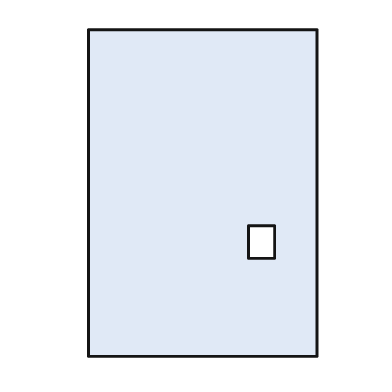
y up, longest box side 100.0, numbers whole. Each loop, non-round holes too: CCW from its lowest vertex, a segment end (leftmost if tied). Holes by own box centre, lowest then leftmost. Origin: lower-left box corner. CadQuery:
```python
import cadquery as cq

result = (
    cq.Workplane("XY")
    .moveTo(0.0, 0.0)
    .lineTo(70.0, 0.0)
    .lineTo(70.0, 100.0)
    .lineTo(0.0, 100.0)
    .close()
    .moveTo(49.0, 30.0)
    .lineTo(57.0, 30.0)
    .lineTo(57.0, 40.0)
    .lineTo(49.0, 40.0)
    .close()
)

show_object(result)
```